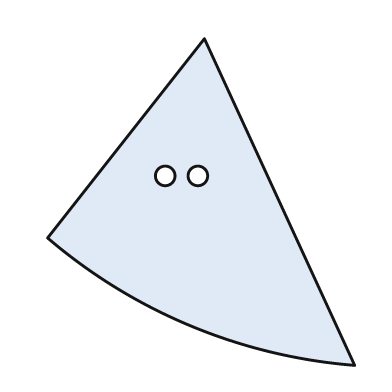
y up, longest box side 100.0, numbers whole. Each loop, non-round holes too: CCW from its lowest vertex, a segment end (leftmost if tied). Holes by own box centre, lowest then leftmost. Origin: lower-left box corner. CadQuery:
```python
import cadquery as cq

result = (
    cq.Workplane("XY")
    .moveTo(94.0, 0.0)
    .lineTo(48.0, 100.0)
    .lineTo(0.0, 39.0)
    .threePointArc((44.0, 12.0), (94.0, 0.0))
    .close()
    .moveTo(36.0, 58.0)
    .circle(3.0)
    .moveTo(46.0, 58.0)
    .circle(3.0)
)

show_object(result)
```